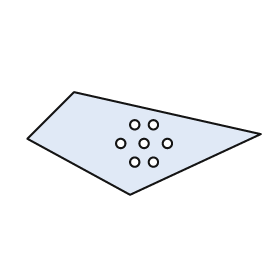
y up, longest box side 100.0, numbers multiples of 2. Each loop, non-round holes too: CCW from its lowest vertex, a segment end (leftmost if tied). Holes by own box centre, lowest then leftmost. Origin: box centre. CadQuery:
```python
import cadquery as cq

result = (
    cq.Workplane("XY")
    .moveTo(-6.0, -22.0)
    .lineTo(50.0, 4.0)
    .lineTo(-30.0, 22.0)
    .lineTo(-50.0, 2.0)
    .close()
    .moveTo(-4.0, -8.0)
    .circle(2.0)
    .moveTo(4.0, -8.0)
    .circle(2.0)
    .moveTo(-10.0, 0.0)
    .circle(2.0)
    .moveTo(0.0, 0.0)
    .circle(2.0)
    .moveTo(10.0, 0.0)
    .circle(2.0)
    .moveTo(-4.0, 8.0)
    .circle(2.0)
    .moveTo(4.0, 8.0)
    .circle(2.0)
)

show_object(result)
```